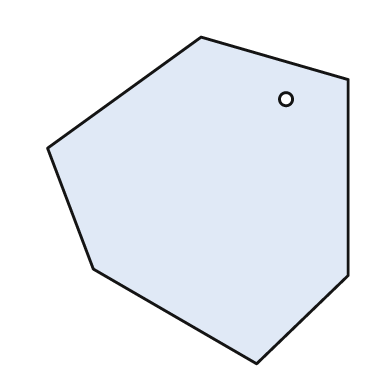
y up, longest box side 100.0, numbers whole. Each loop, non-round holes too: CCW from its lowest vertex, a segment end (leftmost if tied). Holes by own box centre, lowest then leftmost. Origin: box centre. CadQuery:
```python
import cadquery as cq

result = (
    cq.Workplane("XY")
    .moveTo(18.0, -50.0)
    .lineTo(46.0, -23.0)
    .lineTo(46.0, 37.0)
    .lineTo(1.0, 50.0)
    .lineTo(-46.0, 16.0)
    .lineTo(-32.0, -21.0)
    .close()
    .moveTo(27.0, 31.0)
    .circle(2.0)
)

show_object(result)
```